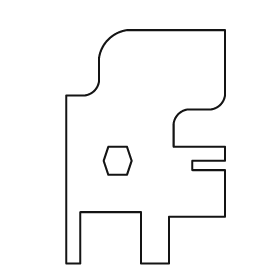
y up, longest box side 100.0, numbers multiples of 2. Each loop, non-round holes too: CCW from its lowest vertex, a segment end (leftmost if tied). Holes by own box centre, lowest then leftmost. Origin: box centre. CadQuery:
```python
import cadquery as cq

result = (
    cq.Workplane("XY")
    .moveTo(-34.0, -50.0)
    .lineTo(-28.0, -50.0)
    .lineTo(-28.0, -28.0)
    .lineTo(-2.0, -28.0)
    .lineTo(-2.0, -50.0)
    .lineTo(10.0, -50.0)
    .lineTo(10.0, -30.0)
    .lineTo(34.0, -30.0)
    .lineTo(34.0, -10.0)
    .lineTo(20.0, -10.0)
    .lineTo(20.0, -6.0)
    .lineTo(34.0, -6.0)
    .lineTo(34.0, 0.0)
    .lineTo(12.0, 0.0)
    .lineTo(12.0, 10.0)
    .threePointArc((14.0, 14.0), (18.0, 16.0))
    .lineTo(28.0, 16.0)
    .threePointArc((32.0, 18.0), (34.0, 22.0))
    .lineTo(34.0, 50.0)
    .lineTo(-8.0, 50.0)
    .threePointArc((-16.0, 46.0), (-20.0, 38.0))
    .lineTo(-20.0, 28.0)
    .threePointArc((-22.0, 24.0), (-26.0, 22.0))
    .lineTo(-34.0, 22.0)
    .close()
    .moveTo(-16.0, -12.0)
    .lineTo(-8.0, -12.0)
    .lineTo(-6.0, -6.0)
    .lineTo(-8.0, 0.0)
    .lineTo(-16.0, 0.0)
    .lineTo(-18.0, -6.0)
    .close()
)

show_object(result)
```